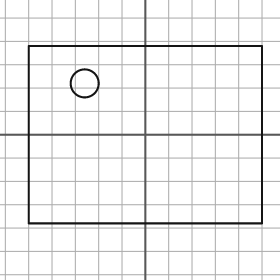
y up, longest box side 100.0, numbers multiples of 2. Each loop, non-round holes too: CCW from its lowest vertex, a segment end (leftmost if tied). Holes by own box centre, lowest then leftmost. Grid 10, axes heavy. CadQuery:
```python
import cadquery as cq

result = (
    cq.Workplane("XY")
    .moveTo(-50.0, -38.0)
    .lineTo(50.0, -38.0)
    .lineTo(50.0, 38.0)
    .lineTo(-50.0, 38.0)
    .close()
    .moveTo(-26.0, 22.0)
    .circle(6.0)
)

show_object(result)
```